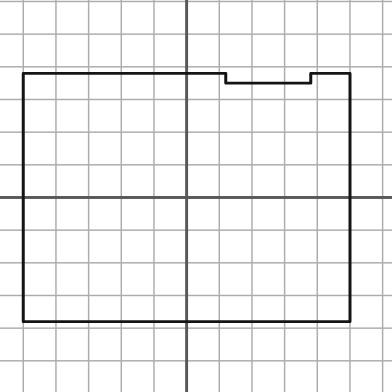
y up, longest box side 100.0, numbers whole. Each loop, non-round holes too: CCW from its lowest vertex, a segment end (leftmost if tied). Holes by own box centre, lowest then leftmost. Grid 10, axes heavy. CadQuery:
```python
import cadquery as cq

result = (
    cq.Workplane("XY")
    .moveTo(-50.0, -38.0)
    .lineTo(50.0, -38.0)
    .lineTo(50.0, 38.0)
    .lineTo(38.0, 38.0)
    .lineTo(38.0, 35.0)
    .lineTo(12.0, 35.0)
    .lineTo(12.0, 38.0)
    .lineTo(-50.0, 38.0)
    .close()
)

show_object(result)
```